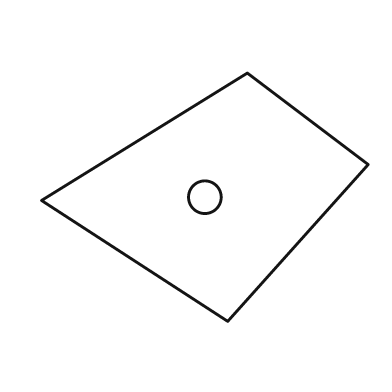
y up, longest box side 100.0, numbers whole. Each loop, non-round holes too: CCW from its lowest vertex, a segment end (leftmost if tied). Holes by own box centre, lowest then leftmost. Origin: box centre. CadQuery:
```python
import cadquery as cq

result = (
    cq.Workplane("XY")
    .moveTo(7.0, -38.0)
    .lineTo(50.0, 10.0)
    .lineTo(13.0, 38.0)
    .lineTo(-50.0, -1.0)
    .close()
    .moveTo(0.0, 0.0)
    .circle(5.0)
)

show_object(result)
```